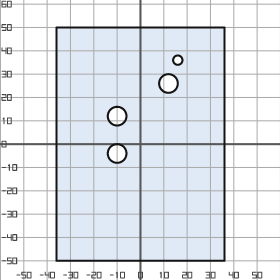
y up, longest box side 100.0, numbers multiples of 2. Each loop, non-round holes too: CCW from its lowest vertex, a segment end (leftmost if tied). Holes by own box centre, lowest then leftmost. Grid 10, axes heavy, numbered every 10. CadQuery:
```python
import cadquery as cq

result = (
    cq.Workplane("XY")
    .moveTo(-36.0, -50.0)
    .lineTo(36.0, -50.0)
    .lineTo(36.0, 50.0)
    .lineTo(-36.0, 50.0)
    .close()
    .moveTo(-10.0, -4.0)
    .circle(4.0)
    .moveTo(-10.0, 12.0)
    .circle(4.0)
    .moveTo(12.0, 26.0)
    .circle(4.0)
    .moveTo(16.0, 36.0)
    .circle(2.0)
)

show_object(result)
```